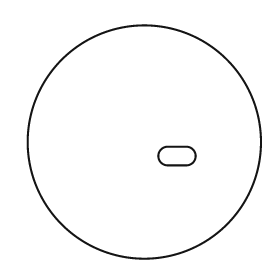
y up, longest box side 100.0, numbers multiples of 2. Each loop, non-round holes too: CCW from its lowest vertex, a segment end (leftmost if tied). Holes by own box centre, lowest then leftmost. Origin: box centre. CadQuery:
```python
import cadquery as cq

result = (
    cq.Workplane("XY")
    .moveTo(0.0, 0.0)
    .circle(50.0)
    .moveTo(10.0, -10.0)
    .lineTo(18.0, -10.0)
    .threePointArc((22.0, -6.0), (18.0, -2.0))
    .lineTo(10.0, -2.0)
    .threePointArc((6.0, -6.0), (10.0, -10.0))
    .close()
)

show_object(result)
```